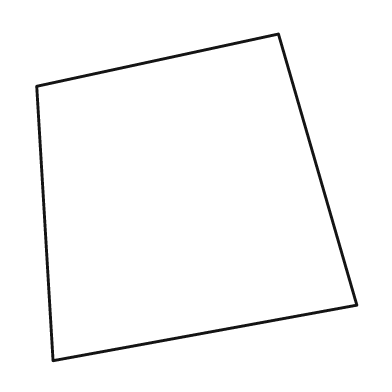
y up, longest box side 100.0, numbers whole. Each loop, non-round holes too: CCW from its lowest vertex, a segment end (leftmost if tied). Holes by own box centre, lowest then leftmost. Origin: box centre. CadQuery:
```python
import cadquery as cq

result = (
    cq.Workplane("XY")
    .moveTo(-44.0, -50.0)
    .lineTo(49.0, -33.0)
    .lineTo(25.0, 50.0)
    .lineTo(-49.0, 34.0)
    .close()
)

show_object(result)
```